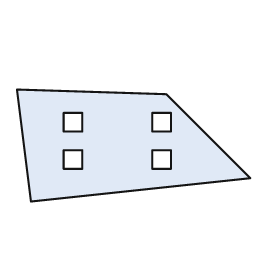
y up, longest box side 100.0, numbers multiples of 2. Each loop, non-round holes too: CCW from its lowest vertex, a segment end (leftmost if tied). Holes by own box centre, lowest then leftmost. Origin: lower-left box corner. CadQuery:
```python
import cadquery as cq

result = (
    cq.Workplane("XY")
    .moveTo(6.0, 0.0)
    .lineTo(100.0, 10.0)
    .lineTo(64.0, 46.0)
    .lineTo(0.0, 48.0)
    .close()
    .moveTo(20.0, 14.0)
    .lineTo(28.0, 14.0)
    .lineTo(28.0, 22.0)
    .lineTo(20.0, 22.0)
    .close()
    .moveTo(58.0, 14.0)
    .lineTo(66.0, 14.0)
    .lineTo(66.0, 22.0)
    .lineTo(58.0, 22.0)
    .close()
    .moveTo(20.0, 30.0)
    .lineTo(28.0, 30.0)
    .lineTo(28.0, 38.0)
    .lineTo(20.0, 38.0)
    .close()
    .moveTo(58.0, 30.0)
    .lineTo(66.0, 30.0)
    .lineTo(66.0, 38.0)
    .lineTo(58.0, 38.0)
    .close()
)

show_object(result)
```